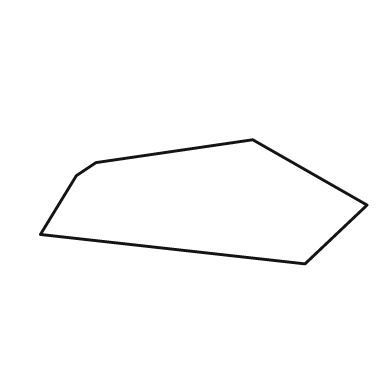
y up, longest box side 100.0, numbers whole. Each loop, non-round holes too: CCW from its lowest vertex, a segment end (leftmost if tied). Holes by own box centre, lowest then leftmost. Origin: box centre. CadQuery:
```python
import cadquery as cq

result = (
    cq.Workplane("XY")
    .moveTo(31.0, -19.0)
    .lineTo(50.0, -1.0)
    .lineTo(15.0, 19.0)
    .lineTo(-33.0, 12.0)
    .lineTo(-39.0, 8.0)
    .lineTo(-50.0, -10.0)
    .close()
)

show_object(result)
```